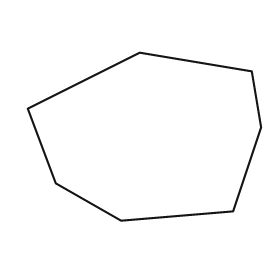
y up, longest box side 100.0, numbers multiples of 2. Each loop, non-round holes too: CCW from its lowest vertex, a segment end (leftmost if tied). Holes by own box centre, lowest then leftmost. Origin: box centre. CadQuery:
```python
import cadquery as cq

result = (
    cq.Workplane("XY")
    .moveTo(-10.0, -36.0)
    .lineTo(38.0, -32.0)
    .lineTo(50.0, 4.0)
    .lineTo(46.0, 28.0)
    .lineTo(-2.0, 36.0)
    .lineTo(-50.0, 12.0)
    .lineTo(-38.0, -20.0)
    .close()
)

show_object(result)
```